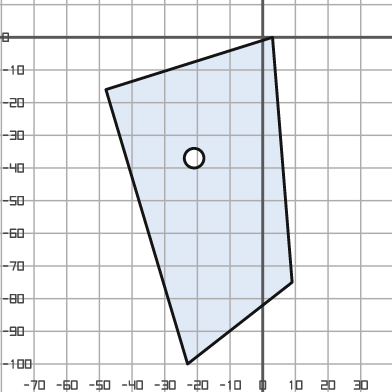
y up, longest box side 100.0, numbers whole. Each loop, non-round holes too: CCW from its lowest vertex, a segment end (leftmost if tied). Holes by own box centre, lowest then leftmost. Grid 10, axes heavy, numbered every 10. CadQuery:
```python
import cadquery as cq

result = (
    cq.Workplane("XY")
    .moveTo(-23.0, -100.0)
    .lineTo(9.0, -75.0)
    .lineTo(3.0, 0.0)
    .lineTo(-48.0, -16.0)
    .close()
    .moveTo(-21.0, -37.0)
    .circle(3.0)
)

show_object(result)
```